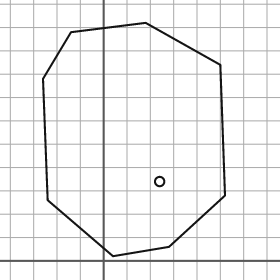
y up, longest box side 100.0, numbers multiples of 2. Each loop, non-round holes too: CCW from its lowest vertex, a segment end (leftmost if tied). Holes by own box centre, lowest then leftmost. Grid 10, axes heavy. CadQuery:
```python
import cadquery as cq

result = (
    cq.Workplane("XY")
    .moveTo(4.0, 2.0)
    .lineTo(28.0, 6.0)
    .lineTo(52.0, 28.0)
    .lineTo(50.0, 84.0)
    .lineTo(18.0, 102.0)
    .lineTo(-14.0, 98.0)
    .lineTo(-26.0, 78.0)
    .lineTo(-24.0, 26.0)
    .close()
    .moveTo(24.0, 34.0)
    .circle(2.0)
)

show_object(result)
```